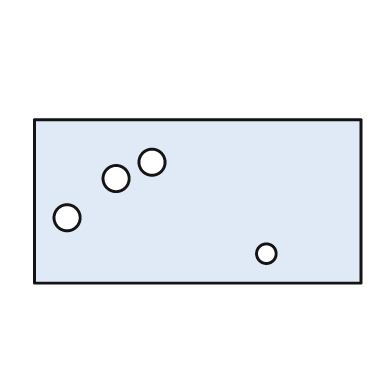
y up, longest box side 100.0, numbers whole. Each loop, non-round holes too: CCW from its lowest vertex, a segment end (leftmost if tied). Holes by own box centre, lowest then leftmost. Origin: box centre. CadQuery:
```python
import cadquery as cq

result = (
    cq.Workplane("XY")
    .moveTo(-50.0, -25.0)
    .lineTo(50.0, -25.0)
    .lineTo(50.0, 25.0)
    .lineTo(-50.0, 25.0)
    .close()
    .moveTo(21.0, -16.0)
    .circle(3.0)
    .moveTo(-40.0, -5.0)
    .circle(4.0)
    .moveTo(-25.0, 7.0)
    .circle(4.0)
    .moveTo(-14.0, 12.0)
    .circle(4.0)
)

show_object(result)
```